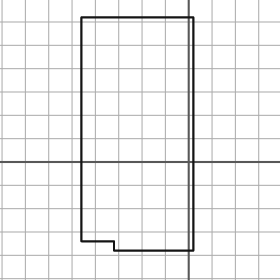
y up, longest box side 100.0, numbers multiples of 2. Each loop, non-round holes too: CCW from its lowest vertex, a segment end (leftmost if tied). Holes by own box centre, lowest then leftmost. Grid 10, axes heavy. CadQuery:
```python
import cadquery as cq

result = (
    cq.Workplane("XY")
    .moveTo(-32.0, -38.0)
    .lineTo(2.0, -38.0)
    .lineTo(2.0, 62.0)
    .lineTo(-46.0, 62.0)
    .lineTo(-46.0, -34.0)
    .lineTo(-32.0, -34.0)
    .close()
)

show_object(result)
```